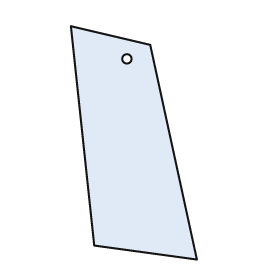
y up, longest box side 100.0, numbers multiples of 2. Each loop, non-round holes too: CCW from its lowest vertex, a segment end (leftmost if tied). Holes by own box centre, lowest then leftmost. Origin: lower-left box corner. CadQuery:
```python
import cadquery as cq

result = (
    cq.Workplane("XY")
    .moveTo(54.0, 0.0)
    .lineTo(34.0, 92.0)
    .lineTo(0.0, 100.0)
    .lineTo(10.0, 6.0)
    .close()
    .moveTo(24.0, 86.0)
    .circle(2.0)
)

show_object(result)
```